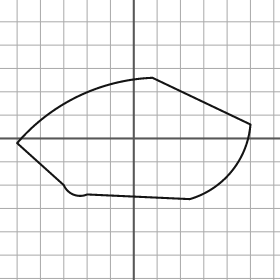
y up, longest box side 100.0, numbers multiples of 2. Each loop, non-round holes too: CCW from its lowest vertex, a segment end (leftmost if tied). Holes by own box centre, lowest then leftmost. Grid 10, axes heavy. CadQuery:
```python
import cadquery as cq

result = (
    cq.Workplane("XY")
    .moveTo(24.0, -26.0)
    .threePointArc((42.0, -14.0), (50.0, 6.0))
    .lineTo(8.0, 26.0)
    .threePointArc((-24.0, 18.0), (-50.0, -2.0))
    .lineTo(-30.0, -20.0)
    .threePointArc((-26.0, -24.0), (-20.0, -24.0))
    .close()
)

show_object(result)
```